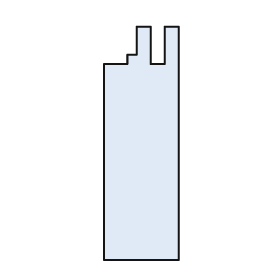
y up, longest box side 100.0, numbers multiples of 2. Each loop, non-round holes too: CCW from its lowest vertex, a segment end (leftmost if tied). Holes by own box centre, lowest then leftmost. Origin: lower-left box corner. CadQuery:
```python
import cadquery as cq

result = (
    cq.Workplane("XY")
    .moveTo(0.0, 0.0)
    .lineTo(32.0, 0.0)
    .lineTo(32.0, 100.0)
    .lineTo(26.0, 100.0)
    .lineTo(26.0, 84.0)
    .lineTo(20.0, 84.0)
    .lineTo(20.0, 100.0)
    .lineTo(14.0, 100.0)
    .lineTo(14.0, 88.0)
    .lineTo(10.0, 88.0)
    .lineTo(10.0, 84.0)
    .lineTo(0.0, 84.0)
    .close()
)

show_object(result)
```